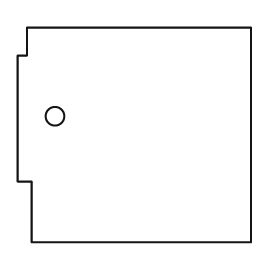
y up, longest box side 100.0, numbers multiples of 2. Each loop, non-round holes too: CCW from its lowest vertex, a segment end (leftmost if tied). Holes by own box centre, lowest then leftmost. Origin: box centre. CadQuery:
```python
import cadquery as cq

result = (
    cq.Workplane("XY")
    .moveTo(-44.0, -46.0)
    .lineTo(50.0, -46.0)
    .lineTo(50.0, 46.0)
    .lineTo(-46.0, 46.0)
    .lineTo(-46.0, 34.0)
    .lineTo(-50.0, 34.0)
    .lineTo(-50.0, -20.0)
    .lineTo(-44.0, -20.0)
    .close()
    .moveTo(-34.0, 8.0)
    .circle(4.0)
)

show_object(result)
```